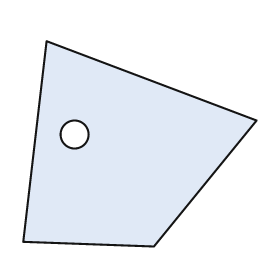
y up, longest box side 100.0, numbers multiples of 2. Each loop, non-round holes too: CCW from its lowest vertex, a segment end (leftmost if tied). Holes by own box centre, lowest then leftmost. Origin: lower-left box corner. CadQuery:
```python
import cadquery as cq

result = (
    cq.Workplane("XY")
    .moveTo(56.0, 0.0)
    .lineTo(100.0, 54.0)
    .lineTo(10.0, 88.0)
    .lineTo(0.0, 2.0)
    .close()
    .moveTo(22.0, 48.0)
    .circle(6.0)
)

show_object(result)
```